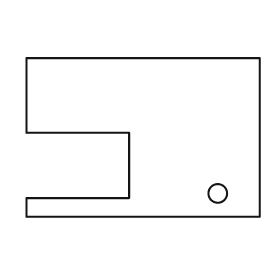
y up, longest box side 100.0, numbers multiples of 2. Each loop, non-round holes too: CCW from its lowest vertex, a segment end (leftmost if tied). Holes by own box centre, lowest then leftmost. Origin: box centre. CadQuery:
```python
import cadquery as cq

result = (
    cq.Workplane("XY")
    .moveTo(-50.0, -34.0)
    .lineTo(50.0, -34.0)
    .lineTo(50.0, 34.0)
    .lineTo(-50.0, 34.0)
    .lineTo(-50.0, 2.0)
    .lineTo(-6.0, 2.0)
    .lineTo(-6.0, -26.0)
    .lineTo(-50.0, -26.0)
    .close()
    .moveTo(32.0, -24.0)
    .circle(4.0)
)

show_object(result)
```